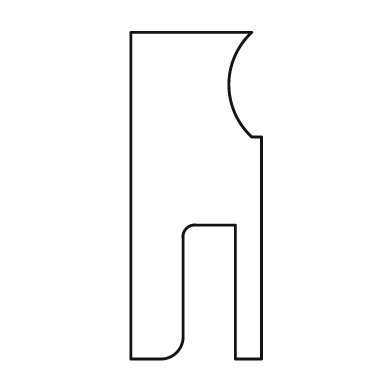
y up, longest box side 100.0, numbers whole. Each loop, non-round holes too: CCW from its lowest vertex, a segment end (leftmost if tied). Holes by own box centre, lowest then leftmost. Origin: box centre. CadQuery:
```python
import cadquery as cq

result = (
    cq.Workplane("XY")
    .moveTo(-20.0, -50.0)
    .lineTo(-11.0, -50.0)
    .threePointArc((-6.0, -48.0), (-4.0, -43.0))
    .lineTo(-4.0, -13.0)
    .threePointArc((-3.0, -10.0), (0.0, -9.0))
    .lineTo(12.0, -9.0)
    .lineTo(12.0, -50.0)
    .lineTo(20.0, -50.0)
    .lineTo(20.0, 18.0)
    .lineTo(17.0, 18.0)
    .threePointArc((10.0, 34.0), (17.0, 50.0))
    .lineTo(-20.0, 50.0)
    .close()
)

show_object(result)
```